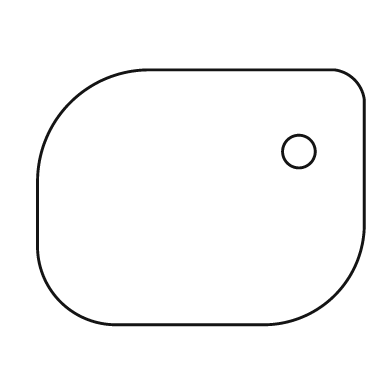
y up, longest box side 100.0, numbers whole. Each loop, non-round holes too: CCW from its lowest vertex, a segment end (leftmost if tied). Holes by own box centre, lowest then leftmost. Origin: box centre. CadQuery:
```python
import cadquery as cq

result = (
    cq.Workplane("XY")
    .moveTo(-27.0, -39.0)
    .lineTo(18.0, -39.0)
    .threePointArc((41.0, -30.0), (50.0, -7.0))
    .lineTo(50.0, 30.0)
    .threePointArc((47.0, 36.0), (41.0, 39.0))
    .lineTo(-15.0, 39.0)
    .threePointArc((-40.0, 29.0), (-50.0, 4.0))
    .lineTo(-50.0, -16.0)
    .threePointArc((-43.0, -32.0), (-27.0, -39.0))
    .close()
    .moveTo(30.0, 14.0)
    .circle(5.0)
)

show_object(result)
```